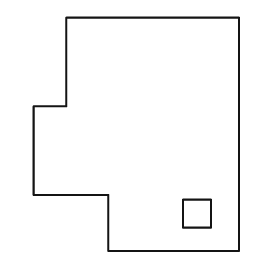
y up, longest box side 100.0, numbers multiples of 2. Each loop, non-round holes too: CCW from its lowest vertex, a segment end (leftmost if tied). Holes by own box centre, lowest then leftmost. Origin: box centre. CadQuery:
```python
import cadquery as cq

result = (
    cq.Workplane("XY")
    .moveTo(-12.0, -50.0)
    .lineTo(44.0, -50.0)
    .lineTo(44.0, 50.0)
    .lineTo(-30.0, 50.0)
    .lineTo(-30.0, 12.0)
    .lineTo(-44.0, 12.0)
    .lineTo(-44.0, -26.0)
    .lineTo(-12.0, -26.0)
    .close()
    .moveTo(20.0, -40.0)
    .lineTo(32.0, -40.0)
    .lineTo(32.0, -28.0)
    .lineTo(20.0, -28.0)
    .close()
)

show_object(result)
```